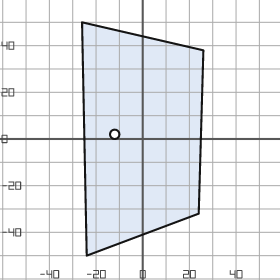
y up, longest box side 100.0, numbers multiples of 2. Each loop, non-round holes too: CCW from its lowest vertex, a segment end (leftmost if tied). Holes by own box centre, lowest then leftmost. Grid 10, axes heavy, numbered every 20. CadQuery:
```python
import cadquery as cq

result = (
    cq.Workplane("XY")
    .moveTo(-24.0, -50.0)
    .lineTo(24.0, -32.0)
    .lineTo(26.0, 38.0)
    .lineTo(-26.0, 50.0)
    .close()
    .moveTo(-12.0, 2.0)
    .circle(2.0)
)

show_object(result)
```